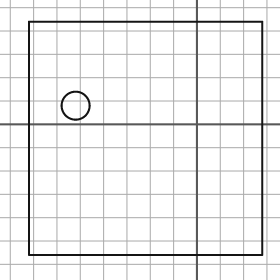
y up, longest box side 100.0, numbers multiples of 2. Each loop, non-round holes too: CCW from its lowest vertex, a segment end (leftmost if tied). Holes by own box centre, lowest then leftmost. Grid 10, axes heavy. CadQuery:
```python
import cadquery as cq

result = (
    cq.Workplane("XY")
    .moveTo(-72.0, -56.0)
    .lineTo(28.0, -56.0)
    .lineTo(28.0, 44.0)
    .lineTo(-72.0, 44.0)
    .close()
    .moveTo(-52.0, 8.0)
    .circle(6.0)
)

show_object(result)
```